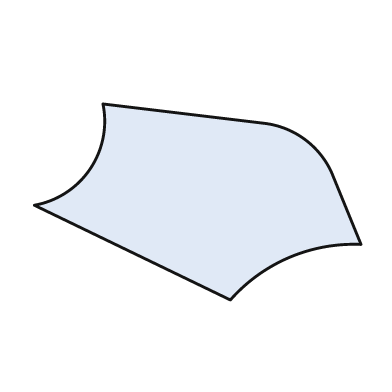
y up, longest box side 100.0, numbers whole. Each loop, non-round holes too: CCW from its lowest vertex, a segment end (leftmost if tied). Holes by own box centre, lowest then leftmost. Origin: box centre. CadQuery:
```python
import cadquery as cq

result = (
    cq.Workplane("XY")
    .moveTo(10.0, -30.0)
    .threePointArc((28.0, -17.0), (50.0, -13.0))
    .lineTo(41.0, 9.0)
    .threePointArc((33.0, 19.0), (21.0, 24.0))
    .lineTo(-29.0, 30.0)
    .threePointArc((-33.0, 10.0), (-50.0, -1.0))
    .close()
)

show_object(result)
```